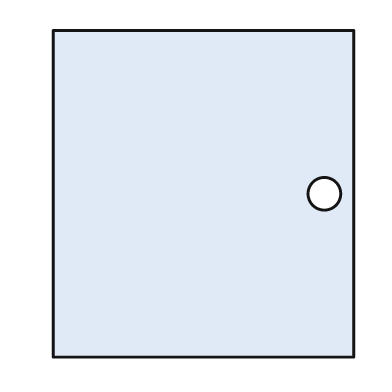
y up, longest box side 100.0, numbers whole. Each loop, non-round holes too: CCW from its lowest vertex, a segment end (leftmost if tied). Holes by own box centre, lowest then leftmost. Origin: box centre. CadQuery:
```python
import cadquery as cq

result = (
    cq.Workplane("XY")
    .moveTo(-46.0, -50.0)
    .lineTo(46.0, -50.0)
    .lineTo(46.0, 50.0)
    .lineTo(-46.0, 50.0)
    .close()
    .moveTo(37.0, 0.0)
    .circle(5.0)
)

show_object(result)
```